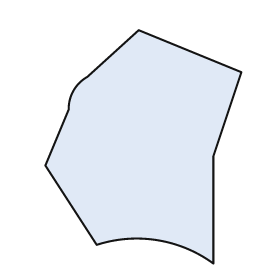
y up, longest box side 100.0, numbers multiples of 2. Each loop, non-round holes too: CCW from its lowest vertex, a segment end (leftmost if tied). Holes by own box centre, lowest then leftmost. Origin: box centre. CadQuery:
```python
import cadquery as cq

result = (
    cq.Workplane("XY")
    .moveTo(30.0, -50.0)
    .lineTo(30.0, -4.0)
    .lineTo(42.0, 32.0)
    .lineTo(-2.0, 50.0)
    .lineTo(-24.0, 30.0)
    .threePointArc((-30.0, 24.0), (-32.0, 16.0))
    .lineTo(-42.0, -8.0)
    .lineTo(-20.0, -42.0)
    .threePointArc((6.0, -40.0), (30.0, -50.0))
    .close()
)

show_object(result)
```